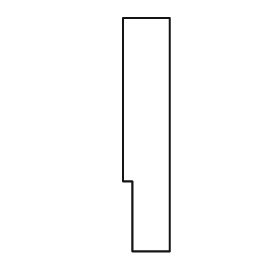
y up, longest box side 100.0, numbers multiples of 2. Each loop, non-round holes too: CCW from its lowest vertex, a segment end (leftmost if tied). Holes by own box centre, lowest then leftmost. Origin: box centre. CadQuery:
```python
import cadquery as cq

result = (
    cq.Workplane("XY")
    .moveTo(-6.0, -50.0)
    .lineTo(10.0, -50.0)
    .lineTo(10.0, 50.0)
    .lineTo(-10.0, 50.0)
    .lineTo(-10.0, -20.0)
    .lineTo(-6.0, -20.0)
    .close()
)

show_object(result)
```